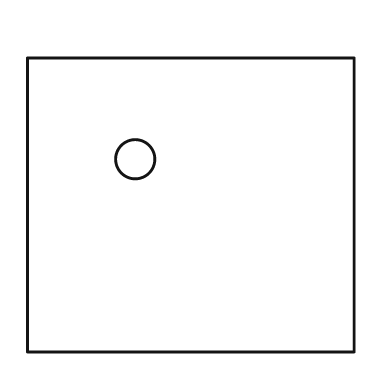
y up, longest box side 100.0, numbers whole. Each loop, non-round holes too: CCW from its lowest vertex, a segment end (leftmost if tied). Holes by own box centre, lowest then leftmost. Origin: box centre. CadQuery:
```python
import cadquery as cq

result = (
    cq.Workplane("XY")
    .moveTo(-50.0, -45.0)
    .lineTo(50.0, -45.0)
    .lineTo(50.0, 45.0)
    .lineTo(-50.0, 45.0)
    .close()
    .moveTo(-17.0, 14.0)
    .circle(6.0)
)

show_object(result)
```